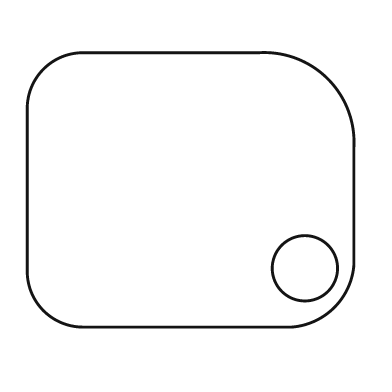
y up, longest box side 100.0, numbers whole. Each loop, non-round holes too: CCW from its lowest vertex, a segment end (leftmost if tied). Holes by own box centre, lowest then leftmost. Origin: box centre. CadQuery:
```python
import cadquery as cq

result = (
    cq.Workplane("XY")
    .moveTo(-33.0, -42.0)
    .lineTo(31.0, -42.0)
    .threePointArc((44.0, -36.0), (50.0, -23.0))
    .lineTo(50.0, 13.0)
    .threePointArc((42.0, 34.0), (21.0, 42.0))
    .lineTo(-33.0, 42.0)
    .threePointArc((-45.0, 37.0), (-50.0, 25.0))
    .lineTo(-50.0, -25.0)
    .threePointArc((-45.0, -37.0), (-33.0, -42.0))
    .close()
    .moveTo(35.0, -24.0)
    .circle(10.0)
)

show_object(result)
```